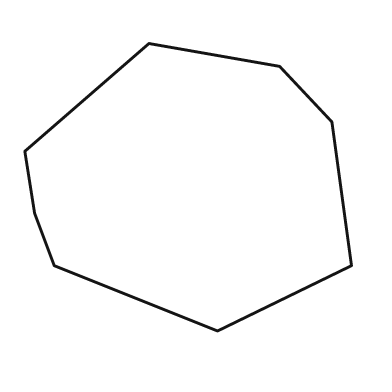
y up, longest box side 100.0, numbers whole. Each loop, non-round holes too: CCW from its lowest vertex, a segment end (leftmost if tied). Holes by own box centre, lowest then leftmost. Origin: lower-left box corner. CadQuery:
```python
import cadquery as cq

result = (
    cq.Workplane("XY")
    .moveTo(59.0, 0.0)
    .lineTo(100.0, 20.0)
    .lineTo(94.0, 64.0)
    .lineTo(78.0, 81.0)
    .lineTo(38.0, 88.0)
    .lineTo(0.0, 55.0)
    .lineTo(3.0, 36.0)
    .lineTo(9.0, 20.0)
    .close()
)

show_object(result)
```